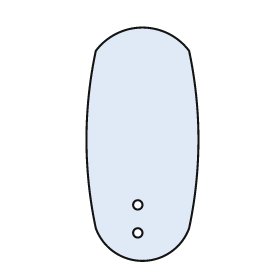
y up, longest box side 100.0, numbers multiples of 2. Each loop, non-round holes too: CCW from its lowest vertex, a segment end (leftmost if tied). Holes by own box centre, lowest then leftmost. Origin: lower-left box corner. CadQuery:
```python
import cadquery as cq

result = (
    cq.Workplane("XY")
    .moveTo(4.0, 14.0)
    .threePointArc((24.0, 0.0), (44.0, 14.0))
    .threePointArc((48.0, 52.0), (44.0, 90.0))
    .threePointArc((24.0, 100.0), (4.0, 90.0))
    .threePointArc((0.0, 52.0), (4.0, 14.0))
    .close()
    .moveTo(22.0, 12.0)
    .circle(2.0)
    .moveTo(22.0, 24.0)
    .circle(2.0)
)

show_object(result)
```